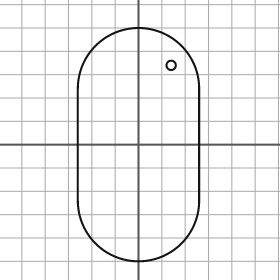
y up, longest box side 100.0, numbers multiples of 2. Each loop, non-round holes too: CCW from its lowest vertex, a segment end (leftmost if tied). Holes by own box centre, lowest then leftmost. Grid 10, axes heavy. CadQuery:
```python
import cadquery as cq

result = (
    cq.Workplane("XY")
    .moveTo(-26.0, -24.0)
    .threePointArc((0.0, -50.0), (26.0, -24.0))
    .lineTo(26.0, 24.0)
    .threePointArc((0.0, 50.0), (-26.0, 24.0))
    .close()
    .moveTo(14.0, 34.0)
    .circle(2.0)
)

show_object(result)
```